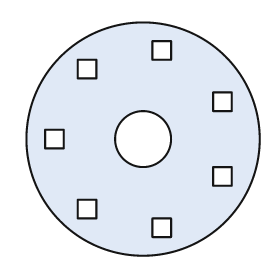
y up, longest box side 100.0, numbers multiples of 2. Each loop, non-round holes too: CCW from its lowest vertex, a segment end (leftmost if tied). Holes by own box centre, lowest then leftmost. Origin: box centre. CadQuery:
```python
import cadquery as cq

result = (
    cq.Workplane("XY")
    .moveTo(0.0, 0.0)
    .circle(50.0)
    .moveTo(4.0, -42.0)
    .lineTo(12.0, -42.0)
    .lineTo(12.0, -34.0)
    .lineTo(4.0, -34.0)
    .close()
    .moveTo(-28.0, -34.0)
    .lineTo(-20.0, -34.0)
    .lineTo(-20.0, -26.0)
    .lineTo(-28.0, -26.0)
    .close()
    .moveTo(30.0, -20.0)
    .lineTo(38.0, -20.0)
    .lineTo(38.0, -12.0)
    .lineTo(30.0, -12.0)
    .close()
    .moveTo(-42.0, -4.0)
    .lineTo(-34.0, -4.0)
    .lineTo(-34.0, 4.0)
    .lineTo(-42.0, 4.0)
    .close()
    .moveTo(0.0, 0.0)
    .circle(12.0)
    .moveTo(30.0, 12.0)
    .lineTo(38.0, 12.0)
    .lineTo(38.0, 20.0)
    .lineTo(30.0, 20.0)
    .close()
    .moveTo(-28.0, 26.0)
    .lineTo(-20.0, 26.0)
    .lineTo(-20.0, 34.0)
    .lineTo(-28.0, 34.0)
    .close()
    .moveTo(4.0, 34.0)
    .lineTo(12.0, 34.0)
    .lineTo(12.0, 42.0)
    .lineTo(4.0, 42.0)
    .close()
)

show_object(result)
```